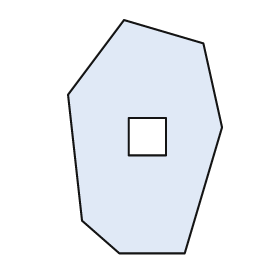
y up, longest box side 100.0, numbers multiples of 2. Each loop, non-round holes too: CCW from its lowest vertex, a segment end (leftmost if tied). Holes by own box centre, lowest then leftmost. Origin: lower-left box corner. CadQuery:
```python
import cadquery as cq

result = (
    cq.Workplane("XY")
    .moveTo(22.0, 0.0)
    .lineTo(50.0, 0.0)
    .lineTo(66.0, 54.0)
    .lineTo(58.0, 90.0)
    .lineTo(24.0, 100.0)
    .lineTo(0.0, 68.0)
    .lineTo(6.0, 14.0)
    .close()
    .moveTo(26.0, 42.0)
    .lineTo(42.0, 42.0)
    .lineTo(42.0, 58.0)
    .lineTo(26.0, 58.0)
    .close()
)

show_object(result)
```